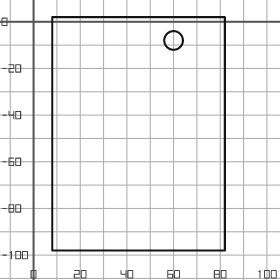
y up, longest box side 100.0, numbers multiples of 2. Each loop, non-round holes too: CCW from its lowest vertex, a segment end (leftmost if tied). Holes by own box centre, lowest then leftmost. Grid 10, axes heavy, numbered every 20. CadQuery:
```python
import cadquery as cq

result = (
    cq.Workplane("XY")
    .moveTo(8.0, -98.0)
    .lineTo(82.0, -98.0)
    .lineTo(82.0, 2.0)
    .lineTo(8.0, 2.0)
    .close()
    .moveTo(60.0, -8.0)
    .circle(4.0)
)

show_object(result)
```